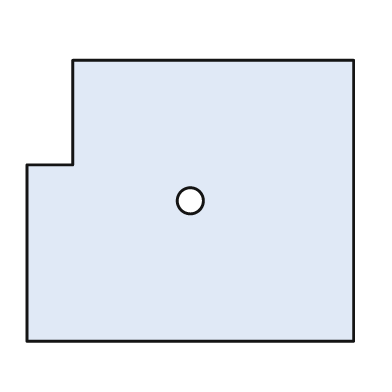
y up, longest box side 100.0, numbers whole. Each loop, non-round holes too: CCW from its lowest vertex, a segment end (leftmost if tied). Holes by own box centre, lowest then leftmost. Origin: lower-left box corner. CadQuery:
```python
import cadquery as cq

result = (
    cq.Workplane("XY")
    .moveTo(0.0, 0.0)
    .lineTo(100.0, 0.0)
    .lineTo(100.0, 86.0)
    .lineTo(14.0, 86.0)
    .lineTo(14.0, 54.0)
    .lineTo(0.0, 54.0)
    .close()
    .moveTo(50.0, 43.0)
    .circle(4.0)
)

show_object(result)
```